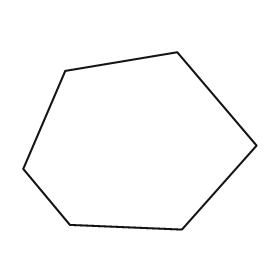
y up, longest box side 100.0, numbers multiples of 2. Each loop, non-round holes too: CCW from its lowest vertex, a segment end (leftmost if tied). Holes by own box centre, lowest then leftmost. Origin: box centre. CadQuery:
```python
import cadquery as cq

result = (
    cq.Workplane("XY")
    .moveTo(18.0, -38.0)
    .lineTo(50.0, -2.0)
    .lineTo(16.0, 38.0)
    .lineTo(-32.0, 30.0)
    .lineTo(-50.0, -12.0)
    .lineTo(-30.0, -36.0)
    .close()
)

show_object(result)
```